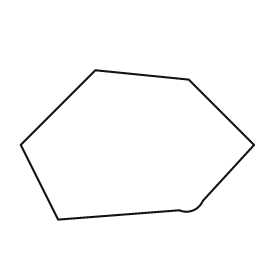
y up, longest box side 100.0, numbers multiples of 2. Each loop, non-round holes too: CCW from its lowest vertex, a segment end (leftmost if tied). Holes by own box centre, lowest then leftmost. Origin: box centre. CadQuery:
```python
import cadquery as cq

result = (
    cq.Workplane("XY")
    .moveTo(-34.0, -32.0)
    .lineTo(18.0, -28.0)
    .threePointArc((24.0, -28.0), (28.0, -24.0))
    .lineTo(50.0, 0.0)
    .lineTo(22.0, 28.0)
    .lineTo(-18.0, 32.0)
    .lineTo(-50.0, 0.0)
    .close()
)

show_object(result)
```